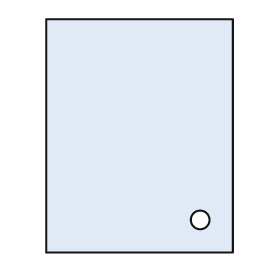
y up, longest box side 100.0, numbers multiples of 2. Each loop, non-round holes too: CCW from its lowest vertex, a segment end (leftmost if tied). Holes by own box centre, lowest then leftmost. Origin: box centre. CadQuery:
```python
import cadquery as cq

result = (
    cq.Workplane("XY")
    .moveTo(-40.0, -50.0)
    .lineTo(40.0, -50.0)
    .lineTo(40.0, 50.0)
    .lineTo(-40.0, 50.0)
    .close()
    .moveTo(26.0, -36.0)
    .circle(4.0)
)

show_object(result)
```